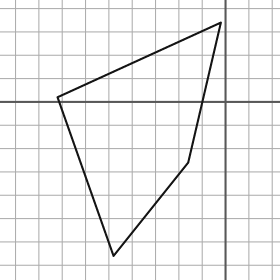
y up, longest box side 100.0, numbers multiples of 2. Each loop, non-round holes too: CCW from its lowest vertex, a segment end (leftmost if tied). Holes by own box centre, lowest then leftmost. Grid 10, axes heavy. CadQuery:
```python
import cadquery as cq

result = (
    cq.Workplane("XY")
    .moveTo(-48.0, -66.0)
    .lineTo(-16.0, -26.0)
    .lineTo(-2.0, 34.0)
    .lineTo(-72.0, 2.0)
    .close()
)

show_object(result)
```